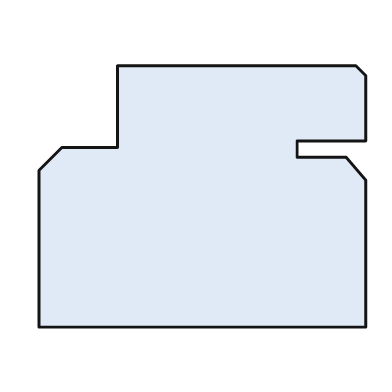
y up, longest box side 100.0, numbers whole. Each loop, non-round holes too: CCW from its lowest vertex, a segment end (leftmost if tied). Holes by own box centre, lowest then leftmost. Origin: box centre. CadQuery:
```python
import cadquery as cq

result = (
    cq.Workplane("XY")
    .moveTo(-50.0, -40.0)
    .lineTo(50.0, -40.0)
    .lineTo(50.0, 5.0)
    .lineTo(44.0, 12.0)
    .lineTo(29.0, 12.0)
    .lineTo(29.0, 17.0)
    .lineTo(50.0, 17.0)
    .lineTo(50.0, 37.0)
    .lineTo(47.0, 40.0)
    .lineTo(-26.0, 40.0)
    .lineTo(-26.0, 15.0)
    .lineTo(-43.0, 15.0)
    .lineTo(-50.0, 8.0)
    .close()
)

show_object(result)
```